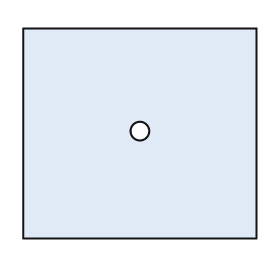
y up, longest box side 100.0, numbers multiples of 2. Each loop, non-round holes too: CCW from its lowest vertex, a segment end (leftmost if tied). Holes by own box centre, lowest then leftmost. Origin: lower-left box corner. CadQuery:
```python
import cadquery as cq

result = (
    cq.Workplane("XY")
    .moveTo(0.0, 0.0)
    .lineTo(100.0, 0.0)
    .lineTo(100.0, 90.0)
    .lineTo(0.0, 90.0)
    .close()
    .moveTo(50.0, 46.0)
    .circle(4.0)
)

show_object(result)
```